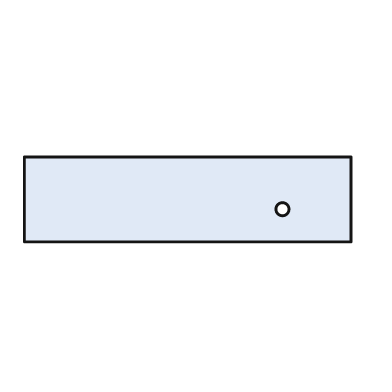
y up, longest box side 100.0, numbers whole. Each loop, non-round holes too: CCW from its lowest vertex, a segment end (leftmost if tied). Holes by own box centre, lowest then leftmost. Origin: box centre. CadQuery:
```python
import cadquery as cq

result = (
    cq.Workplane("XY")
    .moveTo(-50.0, -13.0)
    .lineTo(50.0, -13.0)
    .lineTo(50.0, 13.0)
    .lineTo(-50.0, 13.0)
    .close()
    .moveTo(29.0, -3.0)
    .circle(2.0)
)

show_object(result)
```